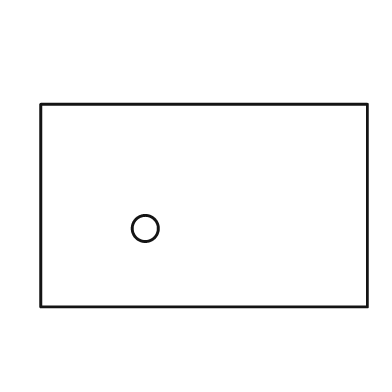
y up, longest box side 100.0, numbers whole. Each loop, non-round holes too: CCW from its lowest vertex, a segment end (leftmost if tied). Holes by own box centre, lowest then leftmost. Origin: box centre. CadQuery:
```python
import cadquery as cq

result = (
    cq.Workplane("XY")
    .moveTo(-50.0, -31.0)
    .lineTo(50.0, -31.0)
    .lineTo(50.0, 31.0)
    .lineTo(-50.0, 31.0)
    .close()
    .moveTo(-18.0, -7.0)
    .circle(4.0)
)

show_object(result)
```